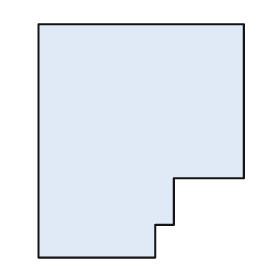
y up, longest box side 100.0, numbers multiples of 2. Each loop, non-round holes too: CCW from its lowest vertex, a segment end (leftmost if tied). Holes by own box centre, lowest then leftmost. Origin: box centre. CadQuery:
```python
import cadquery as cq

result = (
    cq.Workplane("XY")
    .moveTo(-44.0, -50.0)
    .lineTo(6.0, -50.0)
    .lineTo(6.0, -36.0)
    .lineTo(14.0, -36.0)
    .lineTo(14.0, -16.0)
    .lineTo(44.0, -16.0)
    .lineTo(44.0, 50.0)
    .lineTo(-44.0, 50.0)
    .close()
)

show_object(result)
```